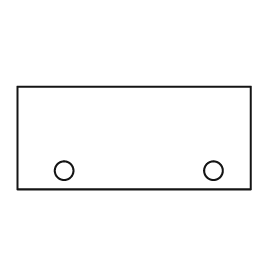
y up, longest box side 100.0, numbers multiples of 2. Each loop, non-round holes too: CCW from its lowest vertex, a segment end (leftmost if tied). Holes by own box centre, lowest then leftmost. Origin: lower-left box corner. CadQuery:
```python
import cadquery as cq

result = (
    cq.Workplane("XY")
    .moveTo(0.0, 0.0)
    .lineTo(100.0, 0.0)
    .lineTo(100.0, 44.0)
    .lineTo(0.0, 44.0)
    .close()
    .moveTo(20.0, 8.0)
    .circle(4.0)
    .moveTo(84.0, 8.0)
    .circle(4.0)
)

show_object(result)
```